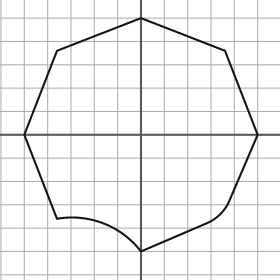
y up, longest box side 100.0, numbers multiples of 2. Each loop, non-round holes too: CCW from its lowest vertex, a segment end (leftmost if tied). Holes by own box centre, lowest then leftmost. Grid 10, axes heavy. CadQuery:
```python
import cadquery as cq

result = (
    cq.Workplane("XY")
    .moveTo(0.0, -50.0)
    .lineTo(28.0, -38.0)
    .threePointArc((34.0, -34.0), (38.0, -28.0))
    .lineTo(50.0, 0.0)
    .lineTo(36.0, 36.0)
    .lineTo(0.0, 50.0)
    .lineTo(-36.0, 36.0)
    .lineTo(-50.0, 0.0)
    .lineTo(-36.0, -36.0)
    .threePointArc((-16.0, -38.0), (0.0, -50.0))
    .close()
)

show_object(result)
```